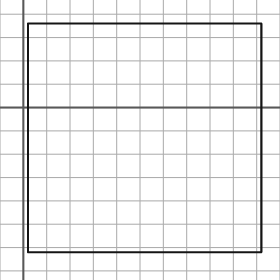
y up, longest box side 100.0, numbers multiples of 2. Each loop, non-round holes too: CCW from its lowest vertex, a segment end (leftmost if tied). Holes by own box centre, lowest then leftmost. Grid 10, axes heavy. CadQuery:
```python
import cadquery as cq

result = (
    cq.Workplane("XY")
    .moveTo(2.0, -62.0)
    .lineTo(102.0, -62.0)
    .lineTo(102.0, 36.0)
    .lineTo(2.0, 36.0)
    .close()
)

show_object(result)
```